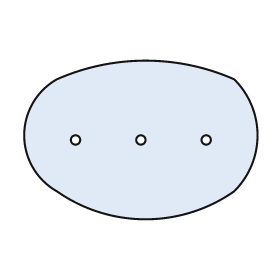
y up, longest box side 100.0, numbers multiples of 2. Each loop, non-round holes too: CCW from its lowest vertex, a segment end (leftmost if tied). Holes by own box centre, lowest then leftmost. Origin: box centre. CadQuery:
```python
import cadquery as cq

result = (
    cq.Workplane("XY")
    .moveTo(-36.0, -22.0)
    .threePointArc((2.0, -34.0), (40.0, -22.0))
    .threePointArc((50.0, 2.0), (40.0, 26.0))
    .threePointArc((2.0, 34.0), (-36.0, 26.0))
    .threePointArc((-50.0, 2.0), (-36.0, -22.0))
    .close()
    .moveTo(-28.0, 0.0)
    .circle(2.0)
    .moveTo(0.0, 0.0)
    .circle(2.0)
    .moveTo(28.0, 0.0)
    .circle(2.0)
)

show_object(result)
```